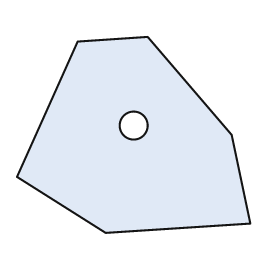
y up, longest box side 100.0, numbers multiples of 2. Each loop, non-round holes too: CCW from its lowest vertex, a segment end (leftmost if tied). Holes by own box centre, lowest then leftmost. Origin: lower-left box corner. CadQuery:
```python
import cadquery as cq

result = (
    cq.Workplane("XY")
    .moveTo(38.0, 0.0)
    .lineTo(100.0, 4.0)
    .lineTo(92.0, 42.0)
    .lineTo(56.0, 84.0)
    .lineTo(26.0, 82.0)
    .lineTo(0.0, 24.0)
    .close()
    .moveTo(50.0, 46.0)
    .circle(6.0)
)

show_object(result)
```